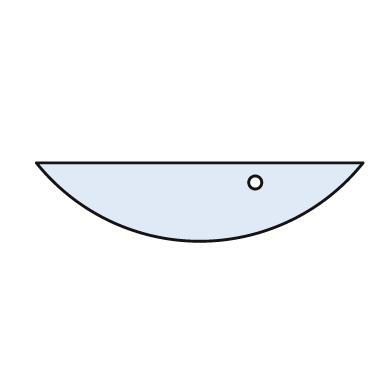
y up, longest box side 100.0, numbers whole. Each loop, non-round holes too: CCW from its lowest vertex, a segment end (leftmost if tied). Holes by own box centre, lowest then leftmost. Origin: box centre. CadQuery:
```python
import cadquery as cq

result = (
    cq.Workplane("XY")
    .moveTo(-50.0, 12.0)
    .threePointArc((0.0, -12.0), (50.0, 12.0))
    .close()
    .moveTo(17.0, 6.0)
    .circle(2.0)
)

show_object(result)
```